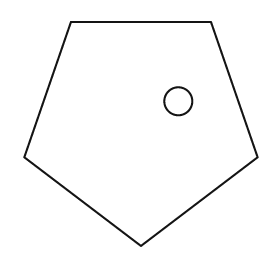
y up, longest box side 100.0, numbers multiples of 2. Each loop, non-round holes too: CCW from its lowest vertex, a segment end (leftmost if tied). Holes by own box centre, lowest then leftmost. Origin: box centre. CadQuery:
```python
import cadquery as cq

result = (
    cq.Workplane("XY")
    .moveTo(0.0, -48.0)
    .lineTo(50.0, -10.0)
    .lineTo(30.0, 48.0)
    .lineTo(-30.0, 48.0)
    .lineTo(-50.0, -10.0)
    .close()
    .moveTo(16.0, 14.0)
    .circle(6.0)
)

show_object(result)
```